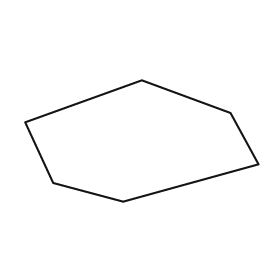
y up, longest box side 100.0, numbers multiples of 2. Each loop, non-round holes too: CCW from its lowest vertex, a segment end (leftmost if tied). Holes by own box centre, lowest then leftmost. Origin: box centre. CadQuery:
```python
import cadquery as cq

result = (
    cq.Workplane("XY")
    .moveTo(-8.0, -26.0)
    .lineTo(50.0, -10.0)
    .lineTo(38.0, 12.0)
    .lineTo(0.0, 26.0)
    .lineTo(-50.0, 8.0)
    .lineTo(-38.0, -18.0)
    .close()
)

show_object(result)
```